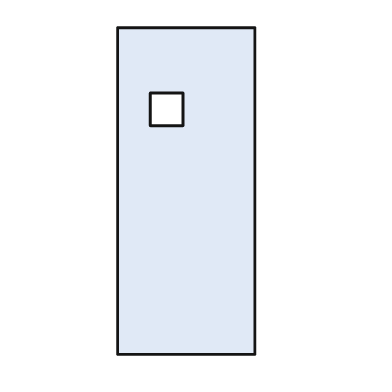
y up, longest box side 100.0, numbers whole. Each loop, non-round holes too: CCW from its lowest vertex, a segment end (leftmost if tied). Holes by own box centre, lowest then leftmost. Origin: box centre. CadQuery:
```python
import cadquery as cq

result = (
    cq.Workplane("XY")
    .moveTo(-21.0, -50.0)
    .lineTo(21.0, -50.0)
    .lineTo(21.0, 50.0)
    .lineTo(-21.0, 50.0)
    .close()
    .moveTo(-11.0, 20.0)
    .lineTo(-1.0, 20.0)
    .lineTo(-1.0, 30.0)
    .lineTo(-11.0, 30.0)
    .close()
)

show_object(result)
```